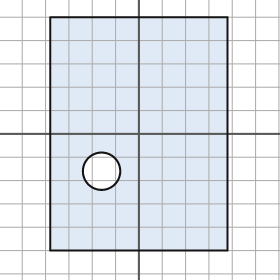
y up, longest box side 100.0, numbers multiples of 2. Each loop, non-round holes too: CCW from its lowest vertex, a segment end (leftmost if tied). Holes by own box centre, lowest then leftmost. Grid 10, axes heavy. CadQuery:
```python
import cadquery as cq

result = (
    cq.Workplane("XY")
    .moveTo(-38.0, -50.0)
    .lineTo(38.0, -50.0)
    .lineTo(38.0, 50.0)
    .lineTo(-38.0, 50.0)
    .close()
    .moveTo(-16.0, -16.0)
    .circle(8.0)
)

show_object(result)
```